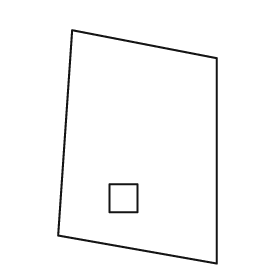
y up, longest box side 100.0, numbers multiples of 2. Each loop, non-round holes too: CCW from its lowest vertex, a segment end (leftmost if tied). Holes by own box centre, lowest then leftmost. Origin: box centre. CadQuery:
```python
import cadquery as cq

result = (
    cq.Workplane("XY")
    .moveTo(34.0, -50.0)
    .lineTo(34.0, 38.0)
    .lineTo(-28.0, 50.0)
    .lineTo(-34.0, -38.0)
    .close()
    .moveTo(-12.0, -28.0)
    .lineTo(0.0, -28.0)
    .lineTo(0.0, -16.0)
    .lineTo(-12.0, -16.0)
    .close()
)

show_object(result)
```